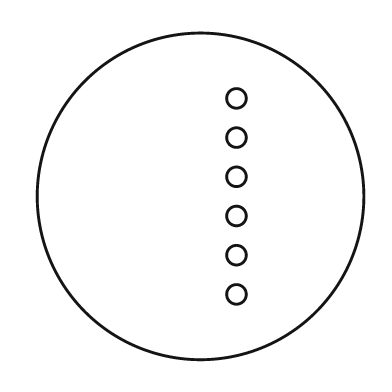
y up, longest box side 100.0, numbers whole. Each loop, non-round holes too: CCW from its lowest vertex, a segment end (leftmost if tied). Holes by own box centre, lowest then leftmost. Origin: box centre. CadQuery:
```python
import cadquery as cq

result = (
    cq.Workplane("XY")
    .moveTo(0.0, 0.0)
    .circle(50.0)
    .moveTo(11.0, -30.0)
    .circle(3.0)
    .moveTo(11.0, -18.0)
    .circle(3.0)
    .moveTo(11.0, -6.0)
    .circle(3.0)
    .moveTo(11.0, 6.0)
    .circle(3.0)
    .moveTo(11.0, 18.0)
    .circle(3.0)
    .moveTo(11.0, 30.0)
    .circle(3.0)
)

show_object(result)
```